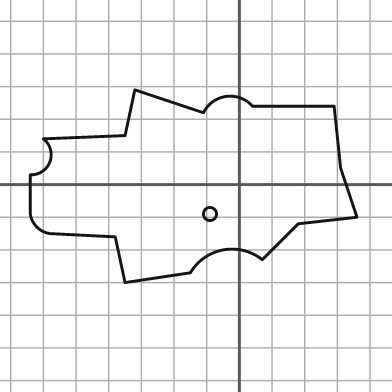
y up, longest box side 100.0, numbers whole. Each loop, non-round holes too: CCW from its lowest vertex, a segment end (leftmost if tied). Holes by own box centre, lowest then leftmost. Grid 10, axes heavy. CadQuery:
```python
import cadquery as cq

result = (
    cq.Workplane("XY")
    .moveTo(-35.0, -30.0)
    .lineTo(-15.0, -27.0)
    .threePointArc((-5.0, -20.0), (7.0, -23.0))
    .lineTo(18.0, -12.0)
    .lineTo(36.0, -10.0)
    .lineTo(31.0, 5.0)
    .lineTo(29.0, 24.0)
    .lineTo(4.0, 24.0)
    .threePointArc((-4.0, 27.0), (-11.0, 22.0))
    .lineTo(-32.0, 29.0)
    .lineTo(-35.0, 15.0)
    .lineTo(-60.0, 14.0)
    .threePointArc((-58.0, 7.0), (-64.0, 3.0))
    .lineTo(-64.0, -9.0)
    .threePointArc((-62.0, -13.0), (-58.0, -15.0))
    .lineTo(-38.0, -16.0)
    .close()
    .moveTo(-9.0, -9.0)
    .circle(2.0)
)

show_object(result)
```